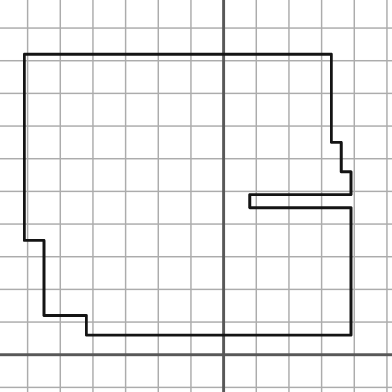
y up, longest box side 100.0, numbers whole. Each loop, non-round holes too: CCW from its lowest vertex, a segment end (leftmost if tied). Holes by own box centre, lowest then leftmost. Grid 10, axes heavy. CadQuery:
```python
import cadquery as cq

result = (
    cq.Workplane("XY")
    .moveTo(-42.0, 6.0)
    .lineTo(39.0, 6.0)
    .lineTo(39.0, 45.0)
    .lineTo(8.0, 45.0)
    .lineTo(8.0, 49.0)
    .lineTo(39.0, 49.0)
    .lineTo(39.0, 56.0)
    .lineTo(36.0, 56.0)
    .lineTo(36.0, 65.0)
    .lineTo(33.0, 65.0)
    .lineTo(33.0, 92.0)
    .lineTo(-61.0, 92.0)
    .lineTo(-61.0, 35.0)
    .lineTo(-55.0, 35.0)
    .lineTo(-55.0, 12.0)
    .lineTo(-42.0, 12.0)
    .close()
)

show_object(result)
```